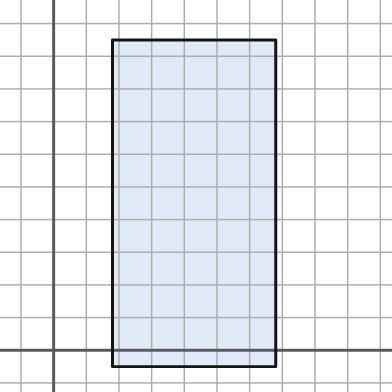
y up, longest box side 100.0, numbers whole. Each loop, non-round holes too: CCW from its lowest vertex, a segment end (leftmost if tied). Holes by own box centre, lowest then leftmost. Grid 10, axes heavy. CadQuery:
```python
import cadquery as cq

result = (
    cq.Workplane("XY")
    .moveTo(18.0, -5.0)
    .lineTo(68.0, -5.0)
    .lineTo(68.0, 95.0)
    .lineTo(18.0, 95.0)
    .close()
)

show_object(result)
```